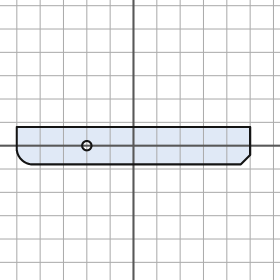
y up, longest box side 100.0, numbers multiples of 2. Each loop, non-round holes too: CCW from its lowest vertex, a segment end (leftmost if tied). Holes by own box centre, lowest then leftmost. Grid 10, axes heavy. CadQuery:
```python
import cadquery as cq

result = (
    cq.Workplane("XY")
    .moveTo(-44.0, -8.0)
    .lineTo(46.0, -8.0)
    .lineTo(50.0, -4.0)
    .lineTo(50.0, 8.0)
    .lineTo(-50.0, 8.0)
    .lineTo(-50.0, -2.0)
    .threePointArc((-48.0, -6.0), (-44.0, -8.0))
    .close()
    .moveTo(-20.0, 0.0)
    .circle(2.0)
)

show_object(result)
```